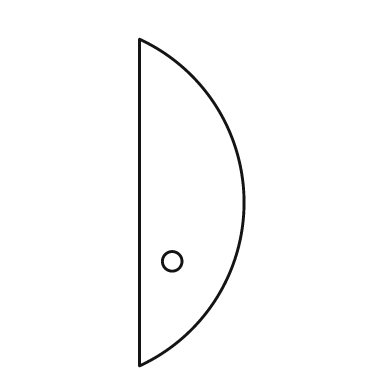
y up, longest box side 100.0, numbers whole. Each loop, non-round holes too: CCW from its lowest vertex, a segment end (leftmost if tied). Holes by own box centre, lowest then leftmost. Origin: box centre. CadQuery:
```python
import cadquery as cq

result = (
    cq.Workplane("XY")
    .moveTo(-16.0, -50.0)
    .threePointArc((16.0, 0.0), (-16.0, 50.0))
    .close()
    .moveTo(-6.0, -18.0)
    .circle(3.0)
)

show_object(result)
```